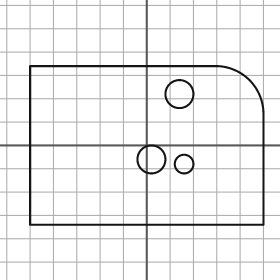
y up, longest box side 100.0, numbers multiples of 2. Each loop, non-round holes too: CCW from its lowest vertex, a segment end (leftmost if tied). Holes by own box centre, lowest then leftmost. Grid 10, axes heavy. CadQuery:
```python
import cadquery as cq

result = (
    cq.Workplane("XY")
    .moveTo(-50.0, -34.0)
    .lineTo(50.0, -34.0)
    .lineTo(50.0, 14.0)
    .threePointArc((44.0, 28.0), (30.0, 34.0))
    .lineTo(-50.0, 34.0)
    .close()
    .moveTo(16.0, -8.0)
    .circle(4.0)
    .moveTo(2.0, -6.0)
    .circle(6.0)
    .moveTo(14.0, 22.0)
    .circle(6.0)
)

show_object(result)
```